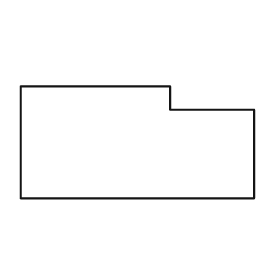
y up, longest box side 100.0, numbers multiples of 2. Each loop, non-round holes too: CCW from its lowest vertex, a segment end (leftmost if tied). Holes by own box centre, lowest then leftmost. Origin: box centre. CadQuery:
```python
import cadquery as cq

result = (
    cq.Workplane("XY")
    .moveTo(-50.0, -24.0)
    .lineTo(50.0, -24.0)
    .lineTo(50.0, 14.0)
    .lineTo(14.0, 14.0)
    .lineTo(14.0, 24.0)
    .lineTo(-50.0, 24.0)
    .close()
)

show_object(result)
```